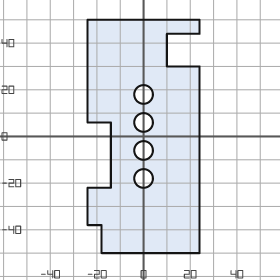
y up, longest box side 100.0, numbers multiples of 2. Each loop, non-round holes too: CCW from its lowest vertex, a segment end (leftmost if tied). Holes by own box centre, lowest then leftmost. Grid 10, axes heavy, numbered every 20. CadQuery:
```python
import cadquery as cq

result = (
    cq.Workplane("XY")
    .moveTo(-18.0, -50.0)
    .lineTo(24.0, -50.0)
    .lineTo(24.0, 30.0)
    .lineTo(10.0, 30.0)
    .lineTo(10.0, 44.0)
    .lineTo(24.0, 44.0)
    .lineTo(24.0, 50.0)
    .lineTo(-24.0, 50.0)
    .lineTo(-24.0, 6.0)
    .lineTo(-14.0, 6.0)
    .lineTo(-14.0, -22.0)
    .lineTo(-24.0, -22.0)
    .lineTo(-24.0, -38.0)
    .lineTo(-18.0, -38.0)
    .close()
    .moveTo(0.0, -18.0)
    .circle(4.0)
    .moveTo(0.0, -6.0)
    .circle(4.0)
    .moveTo(0.0, 6.0)
    .circle(4.0)
    .moveTo(0.0, 18.0)
    .circle(4.0)
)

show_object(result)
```